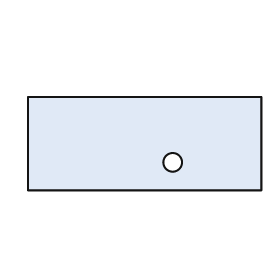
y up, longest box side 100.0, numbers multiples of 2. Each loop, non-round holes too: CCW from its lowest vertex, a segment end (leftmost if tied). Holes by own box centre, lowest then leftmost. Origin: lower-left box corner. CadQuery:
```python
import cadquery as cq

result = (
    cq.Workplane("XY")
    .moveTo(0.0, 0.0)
    .lineTo(100.0, 0.0)
    .lineTo(100.0, 40.0)
    .lineTo(0.0, 40.0)
    .close()
    .moveTo(62.0, 12.0)
    .circle(4.0)
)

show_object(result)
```